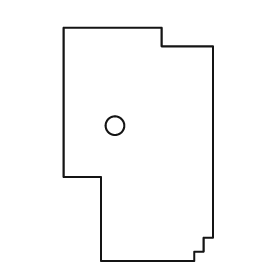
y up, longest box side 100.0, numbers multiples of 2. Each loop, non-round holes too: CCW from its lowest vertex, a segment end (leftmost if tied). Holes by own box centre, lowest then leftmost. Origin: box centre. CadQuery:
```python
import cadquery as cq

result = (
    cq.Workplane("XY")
    .moveTo(-16.0, -50.0)
    .lineTo(24.0, -50.0)
    .lineTo(24.0, -46.0)
    .lineTo(28.0, -46.0)
    .lineTo(28.0, -40.0)
    .lineTo(32.0, -40.0)
    .lineTo(32.0, 42.0)
    .lineTo(10.0, 42.0)
    .lineTo(10.0, 50.0)
    .lineTo(-32.0, 50.0)
    .lineTo(-32.0, -14.0)
    .lineTo(-16.0, -14.0)
    .close()
    .moveTo(-10.0, 8.0)
    .circle(4.0)
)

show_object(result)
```